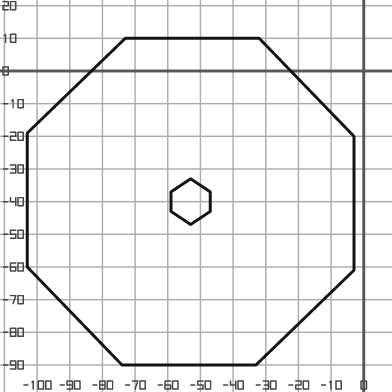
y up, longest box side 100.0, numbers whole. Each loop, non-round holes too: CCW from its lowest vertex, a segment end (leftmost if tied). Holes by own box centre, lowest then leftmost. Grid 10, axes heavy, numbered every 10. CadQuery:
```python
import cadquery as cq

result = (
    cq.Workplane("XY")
    .moveTo(-74.0, -90.0)
    .lineTo(-33.0, -90.0)
    .lineTo(-3.0, -61.0)
    .lineTo(-3.0, -20.0)
    .lineTo(-32.0, 10.0)
    .lineTo(-73.0, 10.0)
    .lineTo(-103.0, -19.0)
    .lineTo(-103.0, -60.0)
    .close()
    .moveTo(-53.0, -47.0)
    .lineTo(-47.0, -43.0)
    .lineTo(-47.0, -37.0)
    .lineTo(-53.0, -33.0)
    .lineTo(-59.0, -37.0)
    .lineTo(-59.0, -43.0)
    .close()
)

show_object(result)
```